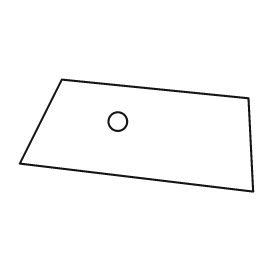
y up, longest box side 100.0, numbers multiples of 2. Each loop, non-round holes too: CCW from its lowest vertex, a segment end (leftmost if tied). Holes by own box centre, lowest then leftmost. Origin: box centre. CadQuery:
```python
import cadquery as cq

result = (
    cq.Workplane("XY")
    .moveTo(50.0, -24.0)
    .lineTo(48.0, 16.0)
    .lineTo(-32.0, 24.0)
    .lineTo(-50.0, -12.0)
    .close()
    .moveTo(-8.0, 6.0)
    .circle(4.0)
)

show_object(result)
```